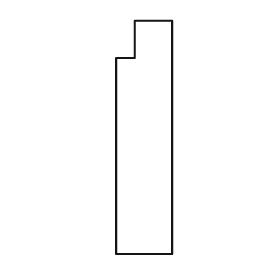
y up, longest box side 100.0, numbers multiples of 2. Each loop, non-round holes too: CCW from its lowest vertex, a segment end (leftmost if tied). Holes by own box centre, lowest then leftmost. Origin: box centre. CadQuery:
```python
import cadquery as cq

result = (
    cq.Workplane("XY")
    .moveTo(-12.0, -50.0)
    .lineTo(12.0, -50.0)
    .lineTo(12.0, 50.0)
    .lineTo(-4.0, 50.0)
    .lineTo(-4.0, 34.0)
    .lineTo(-12.0, 34.0)
    .close()
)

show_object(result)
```